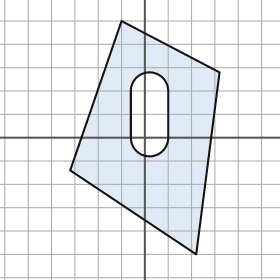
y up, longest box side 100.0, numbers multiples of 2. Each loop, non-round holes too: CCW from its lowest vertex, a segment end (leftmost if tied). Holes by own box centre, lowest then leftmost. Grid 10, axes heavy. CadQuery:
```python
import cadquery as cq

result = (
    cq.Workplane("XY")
    .moveTo(22.0, -50.0)
    .lineTo(32.0, 28.0)
    .lineTo(-10.0, 50.0)
    .lineTo(-32.0, -14.0)
    .close()
    .moveTo(-6.0, 0.0)
    .threePointArc((2.0, -8.0), (10.0, 0.0))
    .lineTo(10.0, 20.0)
    .threePointArc((2.0, 28.0), (-6.0, 20.0))
    .close()
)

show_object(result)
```